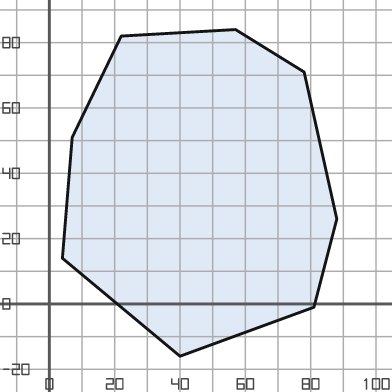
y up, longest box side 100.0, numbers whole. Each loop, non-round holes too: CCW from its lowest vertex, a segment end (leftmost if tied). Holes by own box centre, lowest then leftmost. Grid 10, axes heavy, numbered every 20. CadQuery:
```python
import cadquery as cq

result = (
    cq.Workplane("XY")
    .moveTo(40.0, -16.0)
    .lineTo(81.0, -1.0)
    .lineTo(88.0, 26.0)
    .lineTo(78.0, 71.0)
    .lineTo(57.0, 84.0)
    .lineTo(22.0, 82.0)
    .lineTo(7.0, 51.0)
    .lineTo(4.0, 14.0)
    .close()
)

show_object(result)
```